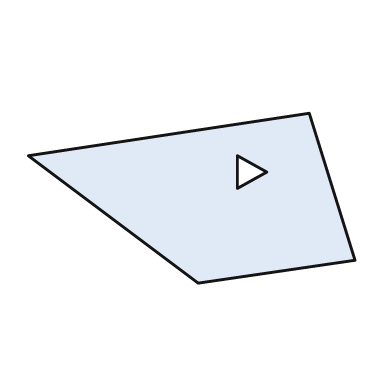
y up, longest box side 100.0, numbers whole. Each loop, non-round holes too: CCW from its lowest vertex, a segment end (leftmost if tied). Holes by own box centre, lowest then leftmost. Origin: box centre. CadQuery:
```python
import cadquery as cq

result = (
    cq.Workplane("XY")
    .moveTo(2.0, -26.0)
    .lineTo(50.0, -19.0)
    .lineTo(36.0, 26.0)
    .lineTo(-50.0, 13.0)
    .close()
    .moveTo(14.0, 3.0)
    .lineTo(23.0, 8.0)
    .lineTo(14.0, 13.0)
    .close()
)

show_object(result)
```